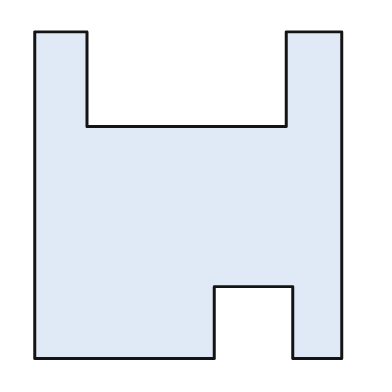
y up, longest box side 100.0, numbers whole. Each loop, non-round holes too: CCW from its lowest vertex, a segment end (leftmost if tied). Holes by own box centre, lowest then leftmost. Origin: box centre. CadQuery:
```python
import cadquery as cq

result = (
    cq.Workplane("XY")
    .moveTo(-47.0, -50.0)
    .lineTo(8.0, -50.0)
    .lineTo(8.0, -28.0)
    .lineTo(32.0, -28.0)
    .lineTo(32.0, -50.0)
    .lineTo(47.0, -50.0)
    .lineTo(47.0, 50.0)
    .lineTo(30.0, 50.0)
    .lineTo(30.0, 21.0)
    .lineTo(-31.0, 21.0)
    .lineTo(-31.0, 50.0)
    .lineTo(-47.0, 50.0)
    .close()
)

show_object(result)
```